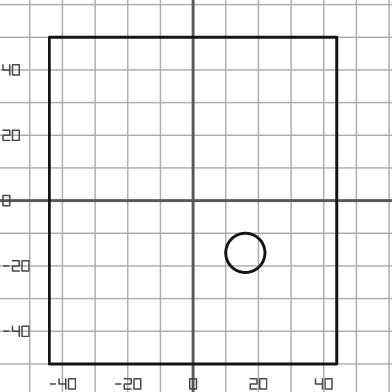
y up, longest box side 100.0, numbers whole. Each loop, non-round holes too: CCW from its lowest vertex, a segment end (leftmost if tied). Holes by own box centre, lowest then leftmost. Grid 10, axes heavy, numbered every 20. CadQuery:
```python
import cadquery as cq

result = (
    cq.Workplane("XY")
    .moveTo(-44.0, -50.0)
    .lineTo(44.0, -50.0)
    .lineTo(44.0, 50.0)
    .lineTo(-44.0, 50.0)
    .close()
    .moveTo(16.0, -16.0)
    .circle(6.0)
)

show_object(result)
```